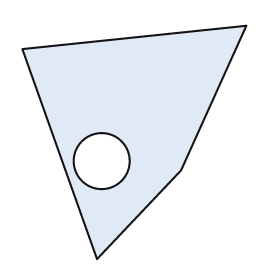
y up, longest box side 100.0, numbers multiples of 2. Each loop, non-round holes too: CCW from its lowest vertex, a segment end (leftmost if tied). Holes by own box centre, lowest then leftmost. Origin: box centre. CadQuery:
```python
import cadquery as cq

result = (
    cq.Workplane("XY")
    .moveTo(-16.0, -50.0)
    .lineTo(20.0, -12.0)
    .lineTo(48.0, 50.0)
    .lineTo(-48.0, 40.0)
    .close()
    .moveTo(-14.0, -8.0)
    .circle(12.0)
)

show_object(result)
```